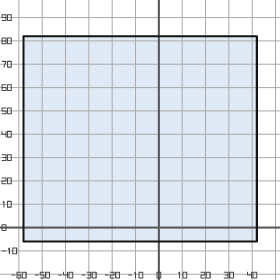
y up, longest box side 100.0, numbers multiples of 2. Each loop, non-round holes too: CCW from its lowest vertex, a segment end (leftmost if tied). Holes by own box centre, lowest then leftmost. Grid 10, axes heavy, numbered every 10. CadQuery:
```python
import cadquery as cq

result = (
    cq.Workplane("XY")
    .moveTo(-58.0, -6.0)
    .lineTo(42.0, -6.0)
    .lineTo(42.0, 82.0)
    .lineTo(-58.0, 82.0)
    .close()
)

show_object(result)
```